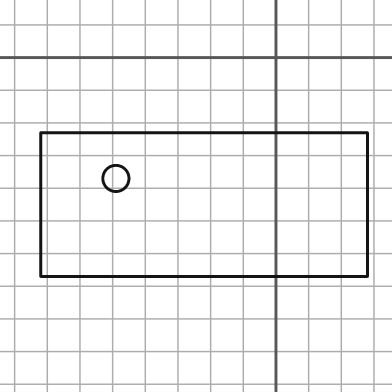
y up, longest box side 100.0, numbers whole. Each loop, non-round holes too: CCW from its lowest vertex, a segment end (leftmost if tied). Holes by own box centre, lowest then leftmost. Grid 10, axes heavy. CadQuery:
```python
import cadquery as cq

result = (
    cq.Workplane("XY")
    .moveTo(-72.0, -67.0)
    .lineTo(28.0, -67.0)
    .lineTo(28.0, -23.0)
    .lineTo(-72.0, -23.0)
    .close()
    .moveTo(-49.0, -37.0)
    .circle(4.0)
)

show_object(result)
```